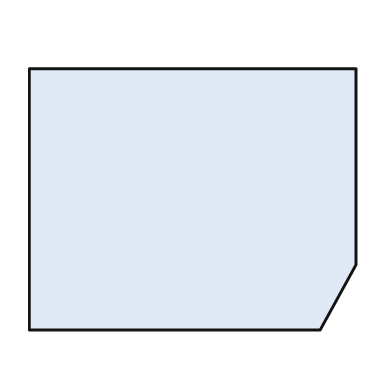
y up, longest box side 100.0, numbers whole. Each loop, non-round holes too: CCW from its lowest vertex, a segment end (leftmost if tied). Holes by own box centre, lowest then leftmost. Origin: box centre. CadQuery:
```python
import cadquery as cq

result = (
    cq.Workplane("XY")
    .moveTo(-50.0, -40.0)
    .lineTo(39.0, -40.0)
    .lineTo(50.0, -20.0)
    .lineTo(50.0, 40.0)
    .lineTo(-50.0, 40.0)
    .close()
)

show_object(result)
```